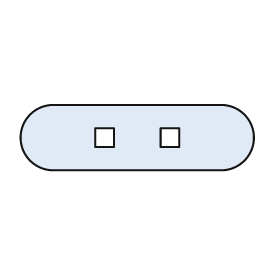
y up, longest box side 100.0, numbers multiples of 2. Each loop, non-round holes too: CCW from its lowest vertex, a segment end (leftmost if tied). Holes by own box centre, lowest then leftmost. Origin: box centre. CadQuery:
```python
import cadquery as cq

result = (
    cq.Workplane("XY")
    .moveTo(-36.0, -14.0)
    .lineTo(36.0, -14.0)
    .threePointArc((50.0, 0.0), (36.0, 14.0))
    .lineTo(-36.0, 14.0)
    .threePointArc((-50.0, 0.0), (-36.0, -14.0))
    .close()
    .moveTo(-18.0, -4.0)
    .lineTo(-10.0, -4.0)
    .lineTo(-10.0, 4.0)
    .lineTo(-18.0, 4.0)
    .close()
    .moveTo(10.0, -4.0)
    .lineTo(18.0, -4.0)
    .lineTo(18.0, 4.0)
    .lineTo(10.0, 4.0)
    .close()
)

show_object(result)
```